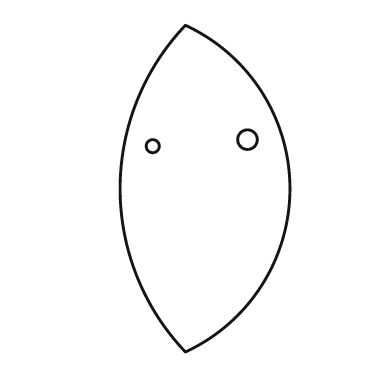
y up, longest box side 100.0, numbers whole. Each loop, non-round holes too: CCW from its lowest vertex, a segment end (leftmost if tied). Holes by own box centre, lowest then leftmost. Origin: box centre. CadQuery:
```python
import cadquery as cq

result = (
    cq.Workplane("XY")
    .moveTo(-6.0, -50.0)
    .threePointArc((26.0, 0.0), (-6.0, 50.0))
    .threePointArc((-26.0, 0.0), (-6.0, -50.0))
    .close()
    .moveTo(-16.0, 13.0)
    .circle(2.0)
    .moveTo(13.0, 15.0)
    .circle(3.0)
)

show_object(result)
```